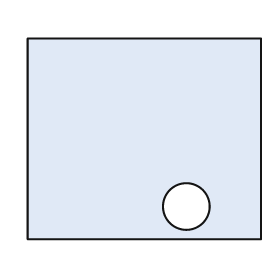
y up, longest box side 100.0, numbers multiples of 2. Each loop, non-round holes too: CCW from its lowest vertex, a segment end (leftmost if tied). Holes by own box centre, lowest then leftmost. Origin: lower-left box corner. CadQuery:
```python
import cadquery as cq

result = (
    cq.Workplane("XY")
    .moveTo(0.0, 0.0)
    .lineTo(100.0, 0.0)
    .lineTo(100.0, 86.0)
    .lineTo(0.0, 86.0)
    .close()
    .moveTo(68.0, 14.0)
    .circle(10.0)
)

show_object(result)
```